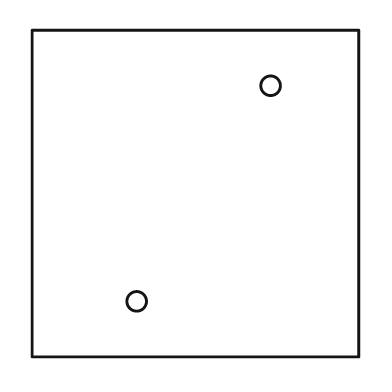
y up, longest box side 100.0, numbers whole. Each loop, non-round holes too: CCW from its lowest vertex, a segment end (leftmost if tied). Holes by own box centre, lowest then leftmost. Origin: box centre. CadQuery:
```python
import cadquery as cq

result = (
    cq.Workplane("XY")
    .moveTo(-50.0, -50.0)
    .lineTo(50.0, -50.0)
    .lineTo(50.0, 50.0)
    .lineTo(-50.0, 50.0)
    .close()
    .moveTo(-18.0, -33.0)
    .circle(3.0)
    .moveTo(23.0, 33.0)
    .circle(3.0)
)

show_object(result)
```